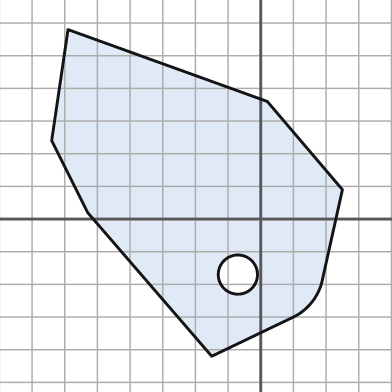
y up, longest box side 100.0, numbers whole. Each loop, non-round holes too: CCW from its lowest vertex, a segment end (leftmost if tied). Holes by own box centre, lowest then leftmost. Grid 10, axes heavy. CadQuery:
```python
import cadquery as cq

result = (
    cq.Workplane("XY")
    .moveTo(-15.0, -42.0)
    .lineTo(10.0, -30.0)
    .threePointArc((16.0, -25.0), (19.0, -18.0))
    .lineTo(25.0, 9.0)
    .lineTo(2.0, 36.0)
    .lineTo(-59.0, 58.0)
    .lineTo(-64.0, 24.0)
    .lineTo(-53.0, 2.0)
    .close()
    .moveTo(-7.0, -17.0)
    .circle(6.0)
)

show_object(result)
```